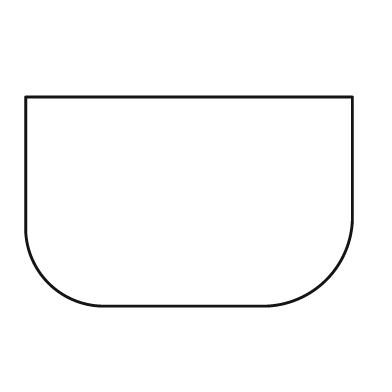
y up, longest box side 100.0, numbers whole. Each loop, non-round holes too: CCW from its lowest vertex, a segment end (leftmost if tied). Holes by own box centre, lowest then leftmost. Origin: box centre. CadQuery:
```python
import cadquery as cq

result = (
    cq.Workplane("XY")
    .moveTo(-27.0, -32.0)
    .lineTo(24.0, -32.0)
    .threePointArc((42.0, -24.0), (50.0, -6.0))
    .lineTo(50.0, 32.0)
    .lineTo(-50.0, 32.0)
    .lineTo(-50.0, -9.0)
    .threePointArc((-43.0, -25.0), (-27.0, -32.0))
    .close()
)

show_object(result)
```